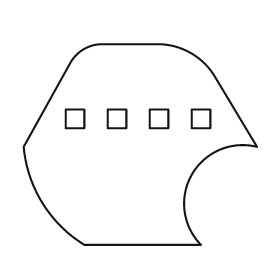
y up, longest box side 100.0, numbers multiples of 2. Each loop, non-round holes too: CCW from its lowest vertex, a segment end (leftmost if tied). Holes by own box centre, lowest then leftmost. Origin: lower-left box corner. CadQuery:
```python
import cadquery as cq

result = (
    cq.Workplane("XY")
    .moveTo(26.0, 0.0)
    .lineTo(76.0, 0.0)
    .threePointArc((72.0, 30.0), (100.0, 42.0))
    .lineTo(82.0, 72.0)
    .threePointArc((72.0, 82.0), (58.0, 86.0))
    .lineTo(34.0, 86.0)
    .threePointArc((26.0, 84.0), (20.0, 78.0))
    .lineTo(0.0, 42.0)
    .threePointArc((8.0, 18.0), (26.0, 0.0))
    .close()
    .moveTo(18.0, 50.0)
    .lineTo(26.0, 50.0)
    .lineTo(26.0, 58.0)
    .lineTo(18.0, 58.0)
    .close()
    .moveTo(36.0, 50.0)
    .lineTo(44.0, 50.0)
    .lineTo(44.0, 58.0)
    .lineTo(36.0, 58.0)
    .close()
    .moveTo(54.0, 50.0)
    .lineTo(62.0, 50.0)
    .lineTo(62.0, 58.0)
    .lineTo(54.0, 58.0)
    .close()
    .moveTo(72.0, 50.0)
    .lineTo(80.0, 50.0)
    .lineTo(80.0, 58.0)
    .lineTo(72.0, 58.0)
    .close()
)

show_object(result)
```